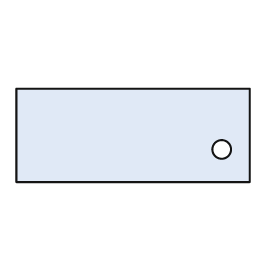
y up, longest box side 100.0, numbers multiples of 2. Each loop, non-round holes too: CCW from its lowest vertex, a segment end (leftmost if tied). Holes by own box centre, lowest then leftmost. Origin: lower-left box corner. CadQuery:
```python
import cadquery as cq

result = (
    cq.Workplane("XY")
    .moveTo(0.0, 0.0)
    .lineTo(100.0, 0.0)
    .lineTo(100.0, 40.0)
    .lineTo(0.0, 40.0)
    .close()
    .moveTo(88.0, 14.0)
    .circle(4.0)
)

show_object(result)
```